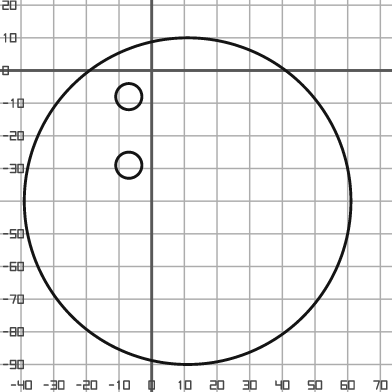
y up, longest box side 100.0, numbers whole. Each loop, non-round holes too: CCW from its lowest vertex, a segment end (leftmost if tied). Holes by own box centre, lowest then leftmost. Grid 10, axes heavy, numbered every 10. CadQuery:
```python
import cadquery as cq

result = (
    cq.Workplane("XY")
    .moveTo(11.0, -40.0)
    .circle(50.0)
    .moveTo(-7.0, -29.0)
    .circle(4.0)
    .moveTo(-7.0, -8.0)
    .circle(4.0)
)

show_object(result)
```